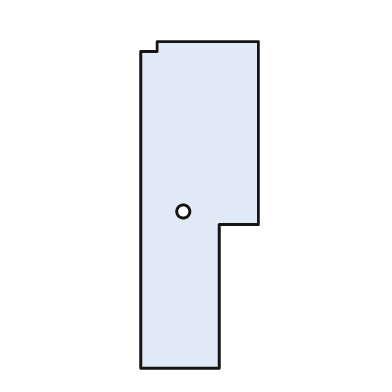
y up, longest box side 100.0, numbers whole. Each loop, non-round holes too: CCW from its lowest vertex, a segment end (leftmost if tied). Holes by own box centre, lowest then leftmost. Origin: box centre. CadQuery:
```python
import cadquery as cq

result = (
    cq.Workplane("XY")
    .moveTo(-18.0, -50.0)
    .lineTo(6.0, -50.0)
    .lineTo(6.0, -6.0)
    .lineTo(18.0, -6.0)
    .lineTo(18.0, 50.0)
    .lineTo(-13.0, 50.0)
    .lineTo(-13.0, 47.0)
    .lineTo(-18.0, 47.0)
    .close()
    .moveTo(-5.0, -2.0)
    .circle(2.0)
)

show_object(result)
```